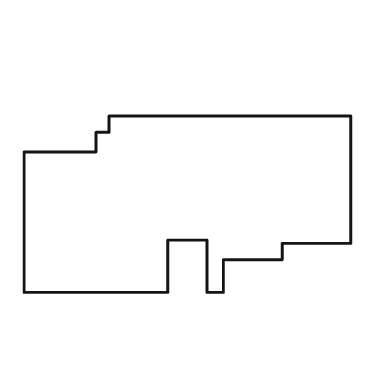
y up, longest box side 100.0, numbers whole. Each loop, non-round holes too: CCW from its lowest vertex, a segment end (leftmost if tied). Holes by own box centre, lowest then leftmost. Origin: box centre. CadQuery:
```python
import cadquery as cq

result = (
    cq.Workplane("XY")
    .moveTo(-50.0, -27.0)
    .lineTo(-6.0, -27.0)
    .lineTo(-6.0, -11.0)
    .lineTo(6.0, -11.0)
    .lineTo(6.0, -27.0)
    .lineTo(11.0, -27.0)
    .lineTo(11.0, -17.0)
    .lineTo(29.0, -17.0)
    .lineTo(29.0, -12.0)
    .lineTo(50.0, -12.0)
    .lineTo(50.0, 27.0)
    .lineTo(-24.0, 27.0)
    .lineTo(-24.0, 22.0)
    .lineTo(-28.0, 22.0)
    .lineTo(-28.0, 16.0)
    .lineTo(-50.0, 16.0)
    .close()
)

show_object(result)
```